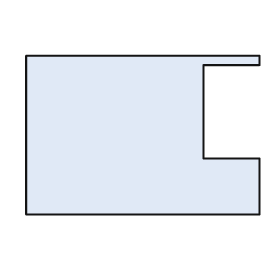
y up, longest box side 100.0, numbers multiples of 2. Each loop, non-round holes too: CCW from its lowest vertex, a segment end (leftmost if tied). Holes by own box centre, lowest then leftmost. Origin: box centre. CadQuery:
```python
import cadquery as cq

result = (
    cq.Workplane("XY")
    .moveTo(-50.0, -34.0)
    .lineTo(50.0, -34.0)
    .lineTo(50.0, -10.0)
    .lineTo(26.0, -10.0)
    .lineTo(26.0, 30.0)
    .lineTo(50.0, 30.0)
    .lineTo(50.0, 34.0)
    .lineTo(-50.0, 34.0)
    .close()
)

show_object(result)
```